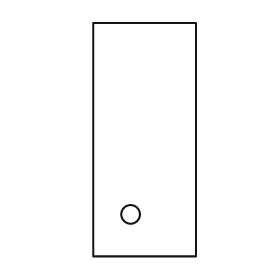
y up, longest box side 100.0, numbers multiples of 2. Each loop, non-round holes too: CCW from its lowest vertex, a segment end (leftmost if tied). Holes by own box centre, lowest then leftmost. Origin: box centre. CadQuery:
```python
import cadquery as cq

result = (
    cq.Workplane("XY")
    .moveTo(-22.0, -50.0)
    .lineTo(22.0, -50.0)
    .lineTo(22.0, 50.0)
    .lineTo(-22.0, 50.0)
    .close()
    .moveTo(-6.0, -32.0)
    .circle(4.0)
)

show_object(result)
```